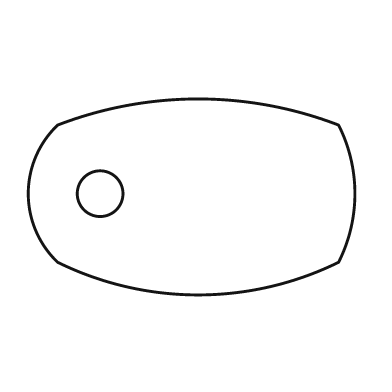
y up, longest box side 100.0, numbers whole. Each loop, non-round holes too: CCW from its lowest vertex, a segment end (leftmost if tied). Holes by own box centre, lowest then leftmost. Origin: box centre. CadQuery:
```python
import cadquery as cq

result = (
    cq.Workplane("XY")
    .moveTo(-41.0, -20.0)
    .threePointArc((2.0, -30.0), (45.0, -20.0))
    .threePointArc((50.0, 1.0), (45.0, 22.0))
    .threePointArc((2.0, 30.0), (-41.0, 22.0))
    .threePointArc((-50.0, 1.0), (-41.0, -20.0))
    .close()
    .moveTo(-28.0, 1.0)
    .circle(7.0)
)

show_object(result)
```